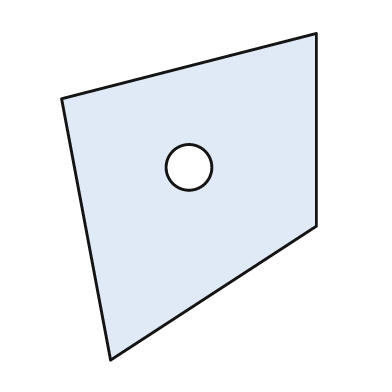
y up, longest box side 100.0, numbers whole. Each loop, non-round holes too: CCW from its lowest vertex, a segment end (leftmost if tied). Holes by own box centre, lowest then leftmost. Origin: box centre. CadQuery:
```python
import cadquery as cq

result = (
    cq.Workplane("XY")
    .moveTo(-24.0, -50.0)
    .lineTo(39.0, -9.0)
    .lineTo(39.0, 50.0)
    .lineTo(-39.0, 30.0)
    .close()
    .moveTo(0.0, 9.0)
    .circle(7.0)
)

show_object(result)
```